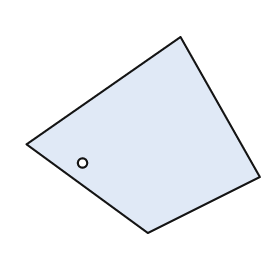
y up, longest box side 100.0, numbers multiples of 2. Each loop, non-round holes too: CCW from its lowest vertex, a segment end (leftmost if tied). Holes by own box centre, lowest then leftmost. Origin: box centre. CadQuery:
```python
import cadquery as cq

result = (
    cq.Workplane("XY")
    .moveTo(2.0, -42.0)
    .lineTo(50.0, -18.0)
    .lineTo(16.0, 42.0)
    .lineTo(-50.0, -4.0)
    .close()
    .moveTo(-26.0, -12.0)
    .circle(2.0)
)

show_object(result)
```